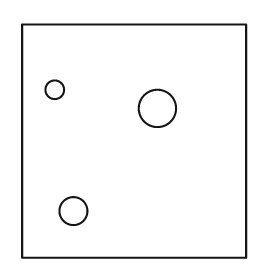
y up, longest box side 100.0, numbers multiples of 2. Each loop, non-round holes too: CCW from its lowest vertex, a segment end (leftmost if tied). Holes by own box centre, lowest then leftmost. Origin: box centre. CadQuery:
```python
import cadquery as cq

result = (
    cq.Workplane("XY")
    .moveTo(-48.0, -50.0)
    .lineTo(48.0, -50.0)
    .lineTo(48.0, 50.0)
    .lineTo(-48.0, 50.0)
    .close()
    .moveTo(-26.0, -30.0)
    .circle(6.0)
    .moveTo(10.0, 14.0)
    .circle(8.0)
    .moveTo(-34.0, 22.0)
    .circle(4.0)
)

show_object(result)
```